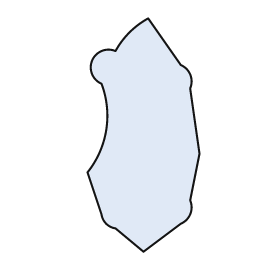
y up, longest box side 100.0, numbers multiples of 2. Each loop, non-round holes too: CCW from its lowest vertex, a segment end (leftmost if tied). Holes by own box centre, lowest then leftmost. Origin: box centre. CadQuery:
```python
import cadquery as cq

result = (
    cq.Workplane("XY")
    .moveTo(0.0, -50.0)
    .lineTo(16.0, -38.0)
    .threePointArc((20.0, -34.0), (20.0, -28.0))
    .lineTo(24.0, -8.0)
    .lineTo(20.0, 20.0)
    .threePointArc((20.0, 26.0), (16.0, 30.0))
    .lineTo(2.0, 50.0)
    .threePointArc((-6.0, 44.0), (-12.0, 36.0))
    .threePointArc((-22.0, 32.0), (-18.0, 22.0))
    .threePointArc((-16.0, 2.0), (-24.0, -16.0))
    .lineTo(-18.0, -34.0)
    .threePointArc((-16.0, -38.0), (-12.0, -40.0))
    .close()
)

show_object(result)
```